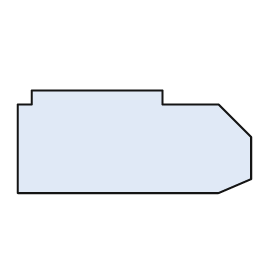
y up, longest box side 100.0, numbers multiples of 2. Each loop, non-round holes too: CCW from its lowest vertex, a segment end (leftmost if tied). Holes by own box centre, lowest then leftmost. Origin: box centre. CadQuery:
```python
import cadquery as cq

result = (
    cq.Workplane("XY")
    .moveTo(-50.0, -22.0)
    .lineTo(36.0, -22.0)
    .lineTo(50.0, -16.0)
    .lineTo(50.0, 2.0)
    .lineTo(36.0, 16.0)
    .lineTo(12.0, 16.0)
    .lineTo(12.0, 22.0)
    .lineTo(-44.0, 22.0)
    .lineTo(-44.0, 16.0)
    .lineTo(-50.0, 16.0)
    .close()
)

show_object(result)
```